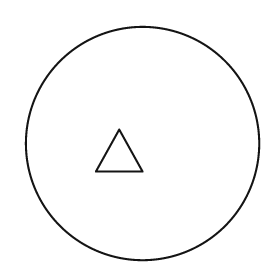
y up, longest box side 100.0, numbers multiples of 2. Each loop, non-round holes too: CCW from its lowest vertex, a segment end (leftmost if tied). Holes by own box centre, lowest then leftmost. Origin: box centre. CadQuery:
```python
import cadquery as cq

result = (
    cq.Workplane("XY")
    .moveTo(0.0, 0.0)
    .circle(50.0)
    .moveTo(-20.0, -12.0)
    .lineTo(0.0, -12.0)
    .lineTo(-10.0, 6.0)
    .close()
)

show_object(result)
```